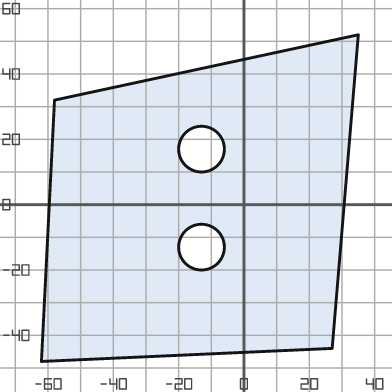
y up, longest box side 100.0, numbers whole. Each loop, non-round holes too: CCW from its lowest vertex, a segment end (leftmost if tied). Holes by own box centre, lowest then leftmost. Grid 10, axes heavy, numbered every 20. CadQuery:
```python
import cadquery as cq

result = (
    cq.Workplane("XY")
    .moveTo(-62.0, -48.0)
    .lineTo(27.0, -44.0)
    .lineTo(35.0, 52.0)
    .lineTo(-58.0, 32.0)
    .close()
    .moveTo(-13.0, -13.0)
    .circle(7.0)
    .moveTo(-13.0, 17.0)
    .circle(7.0)
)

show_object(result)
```